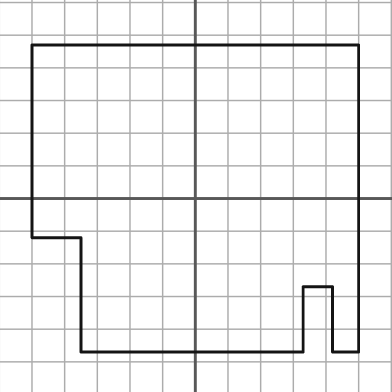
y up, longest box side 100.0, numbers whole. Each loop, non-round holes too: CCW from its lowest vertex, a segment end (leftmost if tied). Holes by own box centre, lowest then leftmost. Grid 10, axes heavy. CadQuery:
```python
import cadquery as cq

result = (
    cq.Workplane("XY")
    .moveTo(-35.0, -47.0)
    .lineTo(33.0, -47.0)
    .lineTo(33.0, -27.0)
    .lineTo(42.0, -27.0)
    .lineTo(42.0, -47.0)
    .lineTo(50.0, -47.0)
    .lineTo(50.0, 47.0)
    .lineTo(-50.0, 47.0)
    .lineTo(-50.0, -12.0)
    .lineTo(-35.0, -12.0)
    .close()
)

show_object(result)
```